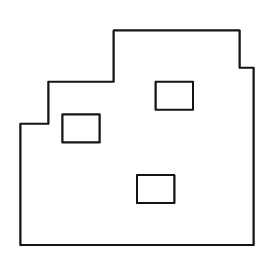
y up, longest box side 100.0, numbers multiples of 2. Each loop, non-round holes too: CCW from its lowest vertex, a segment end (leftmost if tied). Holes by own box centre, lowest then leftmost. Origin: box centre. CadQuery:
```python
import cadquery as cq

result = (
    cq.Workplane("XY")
    .moveTo(-50.0, -46.0)
    .lineTo(50.0, -46.0)
    .lineTo(50.0, 30.0)
    .lineTo(44.0, 30.0)
    .lineTo(44.0, 46.0)
    .lineTo(-10.0, 46.0)
    .lineTo(-10.0, 24.0)
    .lineTo(-38.0, 24.0)
    .lineTo(-38.0, 6.0)
    .lineTo(-50.0, 6.0)
    .close()
    .moveTo(0.0, -28.0)
    .lineTo(16.0, -28.0)
    .lineTo(16.0, -16.0)
    .lineTo(0.0, -16.0)
    .close()
    .moveTo(-32.0, -2.0)
    .lineTo(-16.0, -2.0)
    .lineTo(-16.0, 10.0)
    .lineTo(-32.0, 10.0)
    .close()
    .moveTo(8.0, 12.0)
    .lineTo(24.0, 12.0)
    .lineTo(24.0, 24.0)
    .lineTo(8.0, 24.0)
    .close()
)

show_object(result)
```